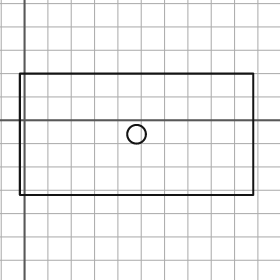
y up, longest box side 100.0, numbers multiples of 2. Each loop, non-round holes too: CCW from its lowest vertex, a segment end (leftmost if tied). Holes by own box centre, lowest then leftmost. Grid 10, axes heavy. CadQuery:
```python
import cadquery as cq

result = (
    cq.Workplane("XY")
    .moveTo(-2.0, -32.0)
    .lineTo(98.0, -32.0)
    .lineTo(98.0, 20.0)
    .lineTo(-2.0, 20.0)
    .close()
    .moveTo(48.0, -6.0)
    .circle(4.0)
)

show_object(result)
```